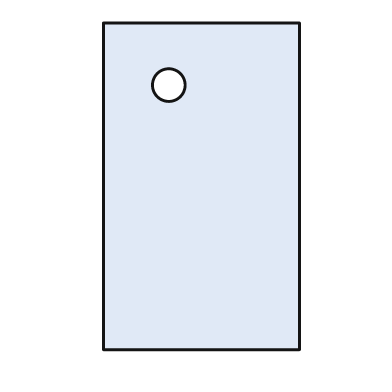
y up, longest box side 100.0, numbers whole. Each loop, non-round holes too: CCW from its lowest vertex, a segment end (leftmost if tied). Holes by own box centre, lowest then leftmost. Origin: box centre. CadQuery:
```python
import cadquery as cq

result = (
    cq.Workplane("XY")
    .moveTo(-30.0, -50.0)
    .lineTo(30.0, -50.0)
    .lineTo(30.0, 50.0)
    .lineTo(-30.0, 50.0)
    .close()
    .moveTo(-10.0, 31.0)
    .circle(5.0)
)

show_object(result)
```